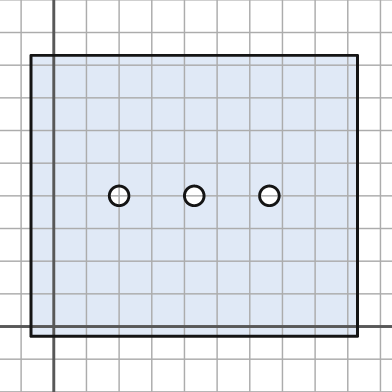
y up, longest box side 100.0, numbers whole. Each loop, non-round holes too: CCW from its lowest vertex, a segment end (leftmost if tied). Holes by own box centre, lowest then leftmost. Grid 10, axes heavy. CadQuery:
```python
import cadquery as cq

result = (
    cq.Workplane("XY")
    .moveTo(-7.0, -3.0)
    .lineTo(93.0, -3.0)
    .lineTo(93.0, 83.0)
    .lineTo(-7.0, 83.0)
    .close()
    .moveTo(20.0, 40.0)
    .circle(3.0)
    .moveTo(43.0, 40.0)
    .circle(3.0)
    .moveTo(66.0, 40.0)
    .circle(3.0)
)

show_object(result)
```